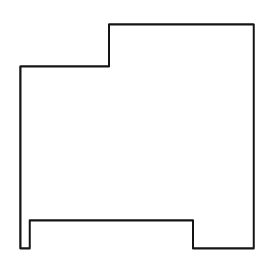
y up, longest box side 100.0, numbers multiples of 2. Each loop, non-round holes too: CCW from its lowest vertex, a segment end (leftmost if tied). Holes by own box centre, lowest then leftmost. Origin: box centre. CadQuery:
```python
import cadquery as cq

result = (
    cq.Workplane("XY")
    .moveTo(-50.0, -48.0)
    .lineTo(-46.0, -48.0)
    .lineTo(-46.0, -36.0)
    .lineTo(24.0, -36.0)
    .lineTo(24.0, -48.0)
    .lineTo(50.0, -48.0)
    .lineTo(50.0, 48.0)
    .lineTo(-12.0, 48.0)
    .lineTo(-12.0, 30.0)
    .lineTo(-50.0, 30.0)
    .close()
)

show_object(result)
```